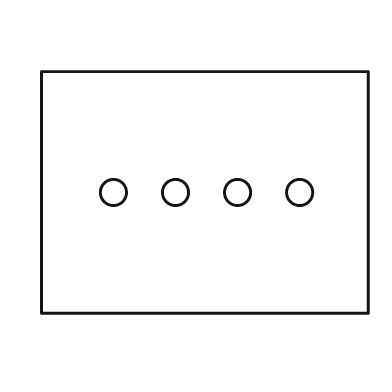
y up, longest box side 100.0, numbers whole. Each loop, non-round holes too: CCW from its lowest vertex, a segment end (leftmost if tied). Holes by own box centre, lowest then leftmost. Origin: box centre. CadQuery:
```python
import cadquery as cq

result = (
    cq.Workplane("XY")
    .moveTo(-50.0, -37.0)
    .lineTo(50.0, -37.0)
    .lineTo(50.0, 37.0)
    .lineTo(-50.0, 37.0)
    .close()
    .moveTo(-28.0, 0.0)
    .circle(4.0)
    .moveTo(-9.0, 0.0)
    .circle(4.0)
    .moveTo(10.0, 0.0)
    .circle(4.0)
    .moveTo(29.0, 0.0)
    .circle(4.0)
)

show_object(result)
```